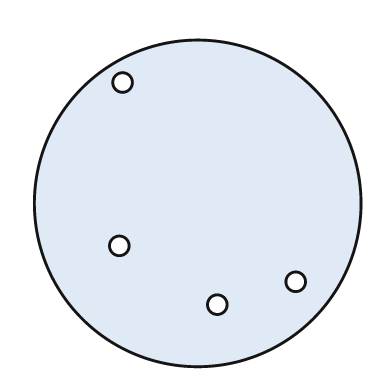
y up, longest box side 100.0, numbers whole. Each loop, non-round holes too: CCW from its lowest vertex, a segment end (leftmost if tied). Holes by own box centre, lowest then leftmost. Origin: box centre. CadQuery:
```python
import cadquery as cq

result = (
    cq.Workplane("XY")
    .moveTo(0.0, 0.0)
    .circle(50.0)
    .moveTo(6.0, -31.0)
    .circle(3.0)
    .moveTo(30.0, -24.0)
    .circle(3.0)
    .moveTo(-24.0, -13.0)
    .circle(3.0)
    .moveTo(-23.0, 37.0)
    .circle(3.0)
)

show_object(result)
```